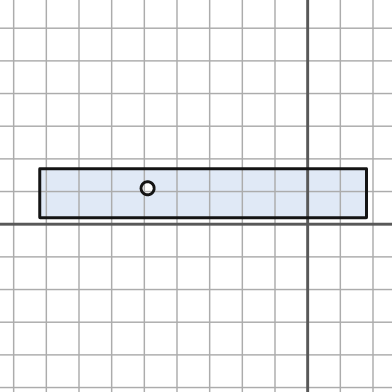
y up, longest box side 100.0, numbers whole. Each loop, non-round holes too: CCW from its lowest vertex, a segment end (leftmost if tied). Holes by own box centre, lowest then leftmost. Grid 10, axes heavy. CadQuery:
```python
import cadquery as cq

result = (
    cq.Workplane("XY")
    .moveTo(-82.0, 2.0)
    .lineTo(18.0, 2.0)
    .lineTo(18.0, 17.0)
    .lineTo(-82.0, 17.0)
    .close()
    .moveTo(-49.0, 11.0)
    .circle(2.0)
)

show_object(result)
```